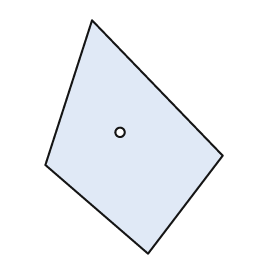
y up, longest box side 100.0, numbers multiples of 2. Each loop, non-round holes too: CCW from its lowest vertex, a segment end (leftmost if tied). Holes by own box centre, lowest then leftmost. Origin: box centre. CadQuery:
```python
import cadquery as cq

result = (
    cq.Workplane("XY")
    .moveTo(6.0, -50.0)
    .lineTo(38.0, -8.0)
    .lineTo(-18.0, 50.0)
    .lineTo(-38.0, -12.0)
    .close()
    .moveTo(-6.0, 2.0)
    .circle(2.0)
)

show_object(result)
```